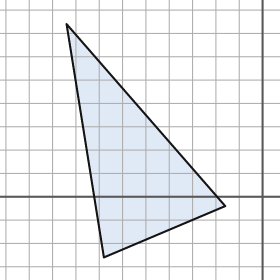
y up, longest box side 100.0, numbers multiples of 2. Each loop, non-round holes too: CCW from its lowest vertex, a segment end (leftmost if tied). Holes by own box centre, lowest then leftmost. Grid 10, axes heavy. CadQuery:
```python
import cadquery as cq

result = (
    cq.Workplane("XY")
    .moveTo(-68.0, -26.0)
    .lineTo(-16.0, -4.0)
    .lineTo(-84.0, 74.0)
    .close()
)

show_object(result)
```